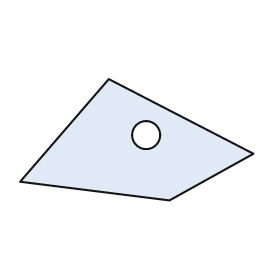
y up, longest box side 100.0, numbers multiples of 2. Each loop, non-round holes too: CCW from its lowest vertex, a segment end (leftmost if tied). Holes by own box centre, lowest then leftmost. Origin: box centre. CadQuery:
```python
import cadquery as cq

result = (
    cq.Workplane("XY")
    .moveTo(14.0, -26.0)
    .lineTo(50.0, -6.0)
    .lineTo(-12.0, 26.0)
    .lineTo(-50.0, -18.0)
    .close()
    .moveTo(4.0, 2.0)
    .circle(6.0)
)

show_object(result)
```